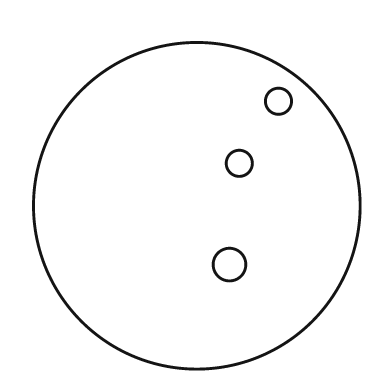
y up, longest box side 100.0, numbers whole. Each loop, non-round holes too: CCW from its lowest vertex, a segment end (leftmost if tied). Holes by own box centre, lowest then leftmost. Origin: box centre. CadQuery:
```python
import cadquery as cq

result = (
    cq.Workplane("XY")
    .moveTo(0.0, 0.0)
    .circle(50.0)
    .moveTo(10.0, -18.0)
    .circle(5.0)
    .moveTo(13.0, 13.0)
    .circle(4.0)
    .moveTo(25.0, 32.0)
    .circle(4.0)
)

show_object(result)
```